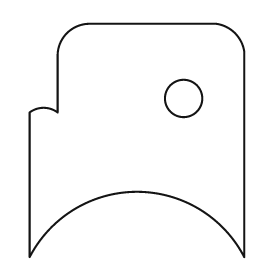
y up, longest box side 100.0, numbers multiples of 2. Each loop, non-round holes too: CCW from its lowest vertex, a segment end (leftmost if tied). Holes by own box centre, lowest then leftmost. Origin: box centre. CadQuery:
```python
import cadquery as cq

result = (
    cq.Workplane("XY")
    .moveTo(-46.0, -50.0)
    .threePointArc((0.0, -22.0), (46.0, -50.0))
    .lineTo(46.0, 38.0)
    .threePointArc((42.0, 46.0), (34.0, 50.0))
    .lineTo(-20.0, 50.0)
    .threePointArc((-30.0, 46.0), (-34.0, 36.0))
    .lineTo(-34.0, 12.0)
    .threePointArc((-40.0, 14.0), (-46.0, 12.0))
    .close()
    .moveTo(20.0, 18.0)
    .circle(8.0)
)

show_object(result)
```